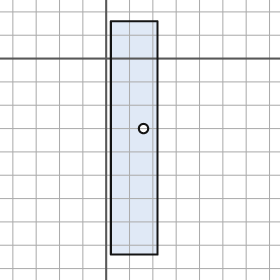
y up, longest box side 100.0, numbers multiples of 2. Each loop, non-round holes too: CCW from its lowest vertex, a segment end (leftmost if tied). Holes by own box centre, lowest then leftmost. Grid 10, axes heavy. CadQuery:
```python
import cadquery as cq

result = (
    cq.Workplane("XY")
    .moveTo(2.0, -84.0)
    .lineTo(22.0, -84.0)
    .lineTo(22.0, 16.0)
    .lineTo(2.0, 16.0)
    .close()
    .moveTo(16.0, -30.0)
    .circle(2.0)
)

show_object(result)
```